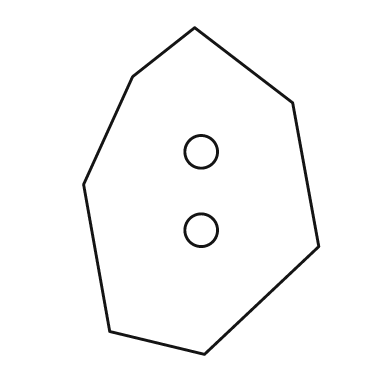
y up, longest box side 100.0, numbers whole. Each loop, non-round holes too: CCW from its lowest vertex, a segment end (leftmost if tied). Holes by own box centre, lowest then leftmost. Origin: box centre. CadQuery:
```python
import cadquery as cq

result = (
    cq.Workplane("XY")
    .moveTo(1.0, -50.0)
    .lineTo(36.0, -17.0)
    .lineTo(28.0, 27.0)
    .lineTo(-2.0, 50.0)
    .lineTo(-21.0, 35.0)
    .lineTo(-36.0, 2.0)
    .lineTo(-28.0, -43.0)
    .close()
    .moveTo(0.0, -12.0)
    .circle(5.0)
    .moveTo(0.0, 12.0)
    .circle(5.0)
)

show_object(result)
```